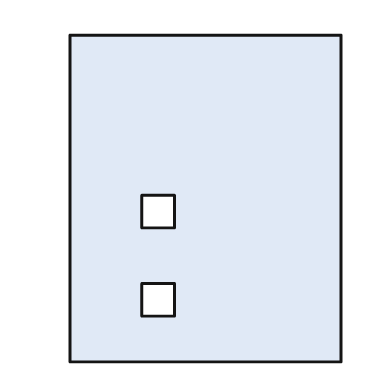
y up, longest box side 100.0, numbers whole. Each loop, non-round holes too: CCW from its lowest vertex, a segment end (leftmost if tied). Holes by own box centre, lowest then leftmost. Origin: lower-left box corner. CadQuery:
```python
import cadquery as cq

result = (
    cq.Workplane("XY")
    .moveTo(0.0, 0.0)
    .lineTo(83.0, 0.0)
    .lineTo(83.0, 100.0)
    .lineTo(0.0, 100.0)
    .close()
    .moveTo(22.0, 14.0)
    .lineTo(32.0, 14.0)
    .lineTo(32.0, 24.0)
    .lineTo(22.0, 24.0)
    .close()
    .moveTo(22.0, 41.0)
    .lineTo(32.0, 41.0)
    .lineTo(32.0, 51.0)
    .lineTo(22.0, 51.0)
    .close()
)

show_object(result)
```